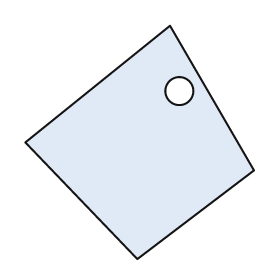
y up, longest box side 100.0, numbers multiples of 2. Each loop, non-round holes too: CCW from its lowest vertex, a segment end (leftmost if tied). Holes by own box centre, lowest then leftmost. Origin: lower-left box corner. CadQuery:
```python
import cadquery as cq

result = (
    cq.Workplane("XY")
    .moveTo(48.0, 0.0)
    .lineTo(98.0, 38.0)
    .lineTo(62.0, 100.0)
    .lineTo(0.0, 50.0)
    .close()
    .moveTo(66.0, 72.0)
    .circle(6.0)
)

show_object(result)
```